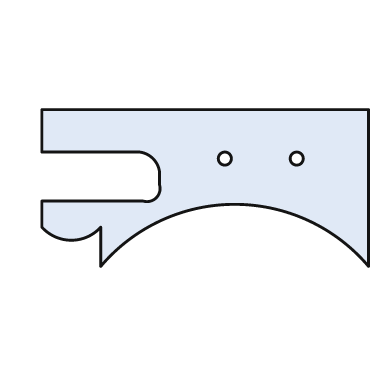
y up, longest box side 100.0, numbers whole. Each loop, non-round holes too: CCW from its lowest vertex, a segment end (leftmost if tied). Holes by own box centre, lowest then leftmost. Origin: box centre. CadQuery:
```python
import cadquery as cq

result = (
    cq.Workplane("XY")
    .moveTo(-32.0, -24.0)
    .threePointArc((9.0, -5.0), (50.0, -24.0))
    .lineTo(50.0, 24.0)
    .lineTo(-50.0, 24.0)
    .lineTo(-50.0, 11.0)
    .lineTo(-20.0, 11.0)
    .threePointArc((-16.0, 9.0), (-14.0, 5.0))
    .lineTo(-14.0, 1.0)
    .threePointArc((-15.0, -3.0), (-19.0, -4.0))
    .lineTo(-50.0, -4.0)
    .lineTo(-50.0, -12.0)
    .threePointArc((-41.0, -16.0), (-32.0, -12.0))
    .close()
    .moveTo(6.0, 9.0)
    .circle(2.0)
    .moveTo(28.0, 9.0)
    .circle(2.0)
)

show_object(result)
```